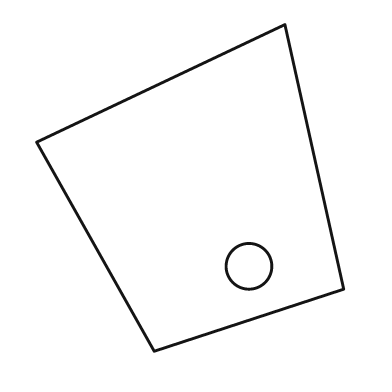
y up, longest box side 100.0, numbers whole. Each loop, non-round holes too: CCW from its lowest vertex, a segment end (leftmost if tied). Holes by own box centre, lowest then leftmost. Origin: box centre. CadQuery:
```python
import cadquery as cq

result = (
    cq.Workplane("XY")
    .moveTo(-11.0, -50.0)
    .lineTo(47.0, -31.0)
    .lineTo(29.0, 50.0)
    .lineTo(-47.0, 14.0)
    .close()
    .moveTo(18.0, -24.0)
    .circle(7.0)
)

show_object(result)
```